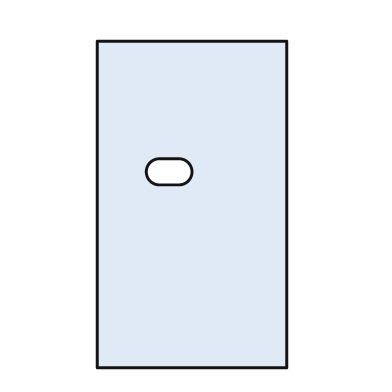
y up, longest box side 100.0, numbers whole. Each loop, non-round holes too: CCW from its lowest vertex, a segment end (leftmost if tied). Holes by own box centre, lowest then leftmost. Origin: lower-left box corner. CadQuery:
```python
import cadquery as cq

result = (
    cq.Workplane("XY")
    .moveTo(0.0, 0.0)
    .lineTo(58.0, 0.0)
    .lineTo(58.0, 100.0)
    .lineTo(0.0, 100.0)
    .close()
    .moveTo(19.0, 56.0)
    .lineTo(25.0, 56.0)
    .threePointArc((29.0, 60.0), (25.0, 64.0))
    .lineTo(19.0, 64.0)
    .threePointArc((15.0, 60.0), (19.0, 56.0))
    .close()
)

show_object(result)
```